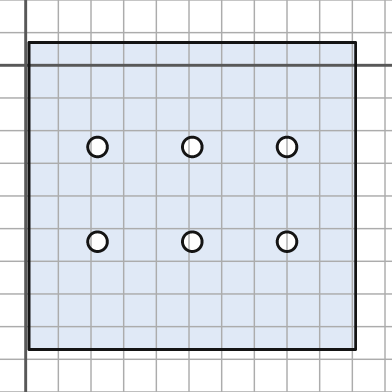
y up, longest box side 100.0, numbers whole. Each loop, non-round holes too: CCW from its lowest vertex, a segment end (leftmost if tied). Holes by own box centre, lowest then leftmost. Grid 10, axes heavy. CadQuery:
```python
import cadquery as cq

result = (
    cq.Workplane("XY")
    .moveTo(1.0, -87.0)
    .lineTo(101.0, -87.0)
    .lineTo(101.0, 7.0)
    .lineTo(1.0, 7.0)
    .close()
    .moveTo(22.0, -54.0)
    .circle(3.0)
    .moveTo(51.0, -54.0)
    .circle(3.0)
    .moveTo(80.0, -54.0)
    .circle(3.0)
    .moveTo(22.0, -25.0)
    .circle(3.0)
    .moveTo(51.0, -25.0)
    .circle(3.0)
    .moveTo(80.0, -25.0)
    .circle(3.0)
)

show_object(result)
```